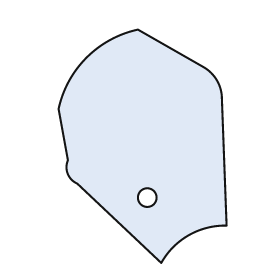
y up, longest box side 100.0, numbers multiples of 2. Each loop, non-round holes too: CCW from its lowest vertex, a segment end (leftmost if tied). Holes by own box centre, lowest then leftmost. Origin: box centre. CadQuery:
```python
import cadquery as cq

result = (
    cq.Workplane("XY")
    .moveTo(8.0, -50.0)
    .threePointArc((20.0, -38.0), (36.0, -34.0))
    .lineTo(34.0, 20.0)
    .threePointArc((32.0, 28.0), (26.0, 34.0))
    .lineTo(-2.0, 50.0)
    .threePointArc((-24.0, 38.0), (-36.0, 16.0))
    .lineTo(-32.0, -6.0)
    .threePointArc((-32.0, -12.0), (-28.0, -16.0))
    .close()
    .moveTo(2.0, -22.0)
    .circle(4.0)
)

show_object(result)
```